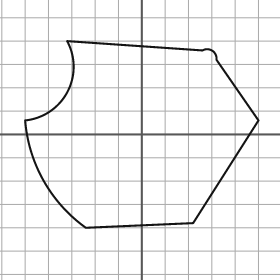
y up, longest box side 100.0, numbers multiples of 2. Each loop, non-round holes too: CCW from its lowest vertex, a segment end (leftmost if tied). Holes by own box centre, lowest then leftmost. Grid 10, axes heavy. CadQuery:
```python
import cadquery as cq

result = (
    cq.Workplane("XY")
    .moveTo(-24.0, -40.0)
    .lineTo(22.0, -38.0)
    .lineTo(50.0, 6.0)
    .lineTo(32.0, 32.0)
    .threePointArc((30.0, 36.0), (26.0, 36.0))
    .lineTo(-32.0, 40.0)
    .threePointArc((-32.0, 18.0), (-50.0, 6.0))
    .threePointArc((-42.0, -20.0), (-24.0, -40.0))
    .close()
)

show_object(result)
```